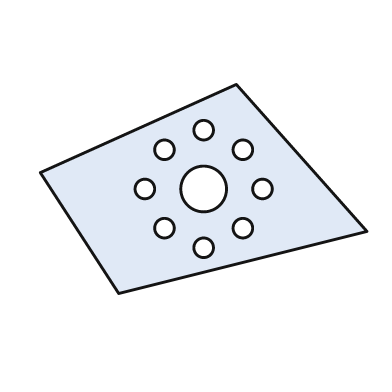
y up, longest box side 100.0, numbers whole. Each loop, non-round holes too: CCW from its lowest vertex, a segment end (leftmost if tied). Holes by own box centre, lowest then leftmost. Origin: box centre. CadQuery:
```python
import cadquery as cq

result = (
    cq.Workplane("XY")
    .moveTo(-26.0, -32.0)
    .lineTo(50.0, -13.0)
    .lineTo(10.0, 32.0)
    .lineTo(-50.0, 5.0)
    .close()
    .moveTo(0.0, -18.0)
    .circle(3.0)
    .moveTo(-12.0, -12.0)
    .circle(3.0)
    .moveTo(12.0, -12.0)
    .circle(3.0)
    .moveTo(-18.0, 0.0)
    .circle(3.0)
    .moveTo(0.0, 0.0)
    .circle(7.0)
    .moveTo(18.0, 0.0)
    .circle(3.0)
    .moveTo(-12.0, 12.0)
    .circle(3.0)
    .moveTo(12.0, 12.0)
    .circle(3.0)
    .moveTo(0.0, 18.0)
    .circle(3.0)
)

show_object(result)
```